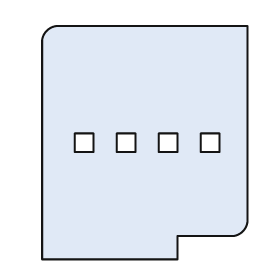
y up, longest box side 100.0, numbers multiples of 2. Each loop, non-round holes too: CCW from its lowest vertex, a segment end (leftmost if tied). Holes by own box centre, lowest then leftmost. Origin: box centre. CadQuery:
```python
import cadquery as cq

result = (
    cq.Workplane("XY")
    .moveTo(-44.0, -50.0)
    .lineTo(14.0, -50.0)
    .lineTo(14.0, -40.0)
    .lineTo(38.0, -40.0)
    .threePointArc((42.0, -38.0), (44.0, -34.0))
    .lineTo(44.0, 50.0)
    .lineTo(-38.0, 50.0)
    .threePointArc((-42.0, 48.0), (-44.0, 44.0))
    .close()
    .moveTo(-30.0, -4.0)
    .lineTo(-22.0, -4.0)
    .lineTo(-22.0, 4.0)
    .lineTo(-30.0, 4.0)
    .close()
    .moveTo(-12.0, -4.0)
    .lineTo(-4.0, -4.0)
    .lineTo(-4.0, 4.0)
    .lineTo(-12.0, 4.0)
    .close()
    .moveTo(6.0, -4.0)
    .lineTo(14.0, -4.0)
    .lineTo(14.0, 4.0)
    .lineTo(6.0, 4.0)
    .close()
    .moveTo(24.0, -4.0)
    .lineTo(32.0, -4.0)
    .lineTo(32.0, 4.0)
    .lineTo(24.0, 4.0)
    .close()
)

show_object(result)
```